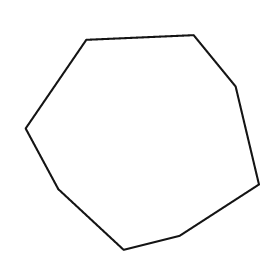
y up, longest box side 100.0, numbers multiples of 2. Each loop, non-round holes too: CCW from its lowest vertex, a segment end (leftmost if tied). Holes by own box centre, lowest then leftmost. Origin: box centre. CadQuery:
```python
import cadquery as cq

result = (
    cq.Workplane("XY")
    .moveTo(-8.0, -46.0)
    .lineTo(16.0, -40.0)
    .lineTo(50.0, -18.0)
    .lineTo(40.0, 24.0)
    .lineTo(22.0, 46.0)
    .lineTo(-24.0, 44.0)
    .lineTo(-50.0, 6.0)
    .lineTo(-36.0, -20.0)
    .close()
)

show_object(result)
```